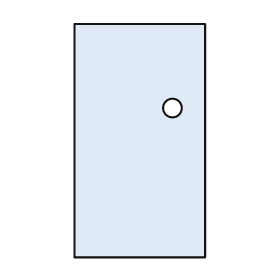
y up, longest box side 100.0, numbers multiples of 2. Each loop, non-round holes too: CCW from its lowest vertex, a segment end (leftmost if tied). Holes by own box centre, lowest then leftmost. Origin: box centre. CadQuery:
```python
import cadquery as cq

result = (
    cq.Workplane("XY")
    .moveTo(-28.0, -50.0)
    .lineTo(28.0, -50.0)
    .lineTo(28.0, 50.0)
    .lineTo(-28.0, 50.0)
    .close()
    .moveTo(14.0, 14.0)
    .circle(4.0)
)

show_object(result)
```